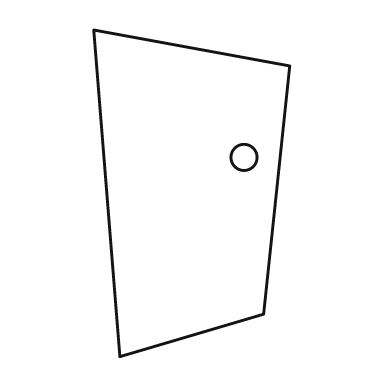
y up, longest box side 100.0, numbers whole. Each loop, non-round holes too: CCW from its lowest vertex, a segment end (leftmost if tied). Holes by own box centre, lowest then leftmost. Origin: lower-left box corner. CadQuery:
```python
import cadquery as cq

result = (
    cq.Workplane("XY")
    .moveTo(8.0, 0.0)
    .lineTo(52.0, 13.0)
    .lineTo(60.0, 89.0)
    .lineTo(0.0, 100.0)
    .close()
    .moveTo(46.0, 61.0)
    .circle(4.0)
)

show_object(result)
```